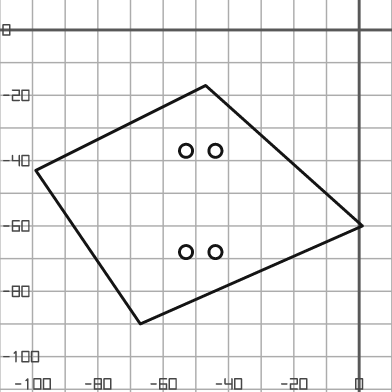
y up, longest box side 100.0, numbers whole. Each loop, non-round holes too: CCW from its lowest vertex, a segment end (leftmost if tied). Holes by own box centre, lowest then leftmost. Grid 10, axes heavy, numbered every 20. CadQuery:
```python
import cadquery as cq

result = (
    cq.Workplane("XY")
    .moveTo(-67.0, -90.0)
    .lineTo(1.0, -60.0)
    .lineTo(-47.0, -17.0)
    .lineTo(-99.0, -43.0)
    .close()
    .moveTo(-53.0, -68.0)
    .circle(2.0)
    .moveTo(-44.0, -68.0)
    .circle(2.0)
    .moveTo(-53.0, -37.0)
    .circle(2.0)
    .moveTo(-44.0, -37.0)
    .circle(2.0)
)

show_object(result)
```